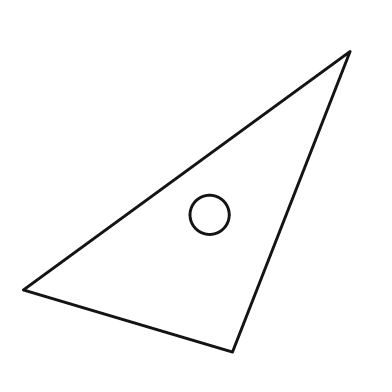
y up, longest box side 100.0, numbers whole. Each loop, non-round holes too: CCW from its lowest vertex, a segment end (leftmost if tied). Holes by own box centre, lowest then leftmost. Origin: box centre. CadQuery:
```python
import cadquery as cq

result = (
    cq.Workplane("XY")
    .moveTo(14.0, -46.0)
    .lineTo(50.0, 46.0)
    .lineTo(-50.0, -27.0)
    .close()
    .moveTo(7.0, -4.0)
    .circle(6.0)
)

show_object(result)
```